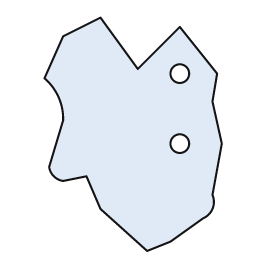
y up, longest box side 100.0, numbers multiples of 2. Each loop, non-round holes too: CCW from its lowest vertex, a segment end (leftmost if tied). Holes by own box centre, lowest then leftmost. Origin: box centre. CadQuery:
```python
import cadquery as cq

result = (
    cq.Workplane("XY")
    .moveTo(6.0, -50.0)
    .lineTo(16.0, -46.0)
    .lineTo(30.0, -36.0)
    .threePointArc((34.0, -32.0), (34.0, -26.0))
    .lineTo(38.0, -4.0)
    .lineTo(34.0, 14.0)
    .lineTo(36.0, 26.0)
    .lineTo(20.0, 46.0)
    .lineTo(2.0, 28.0)
    .lineTo(-14.0, 50.0)
    .lineTo(-30.0, 42.0)
    .lineTo(-38.0, 24.0)
    .threePointArc((-32.0, 16.0), (-30.0, 6.0))
    .lineTo(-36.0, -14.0)
    .threePointArc((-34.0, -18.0), (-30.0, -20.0))
    .lineTo(-20.0, -18.0)
    .lineTo(-14.0, -32.0)
    .close()
    .moveTo(20.0, -4.0)
    .circle(4.0)
    .moveTo(20.0, 26.0)
    .circle(4.0)
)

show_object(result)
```